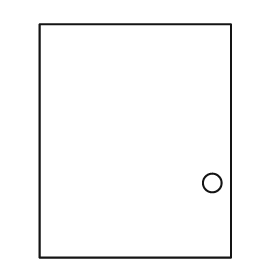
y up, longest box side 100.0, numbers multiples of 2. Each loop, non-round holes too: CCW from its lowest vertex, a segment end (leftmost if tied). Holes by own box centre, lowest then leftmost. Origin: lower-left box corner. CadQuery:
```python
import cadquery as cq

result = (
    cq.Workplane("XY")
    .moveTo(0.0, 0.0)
    .lineTo(82.0, 0.0)
    .lineTo(82.0, 100.0)
    .lineTo(0.0, 100.0)
    .close()
    .moveTo(74.0, 32.0)
    .circle(4.0)
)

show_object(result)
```